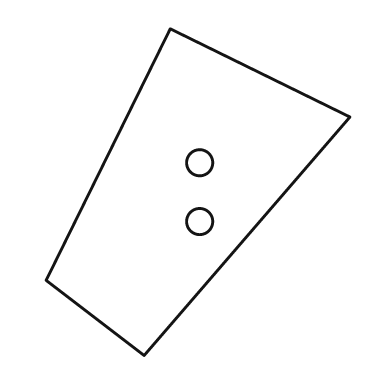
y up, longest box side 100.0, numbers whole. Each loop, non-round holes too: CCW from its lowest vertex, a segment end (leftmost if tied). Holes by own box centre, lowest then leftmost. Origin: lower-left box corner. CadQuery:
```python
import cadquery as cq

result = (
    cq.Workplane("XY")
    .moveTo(30.0, 0.0)
    .lineTo(93.0, 73.0)
    .lineTo(38.0, 100.0)
    .lineTo(0.0, 23.0)
    .close()
    .moveTo(47.0, 41.0)
    .circle(4.0)
    .moveTo(47.0, 59.0)
    .circle(4.0)
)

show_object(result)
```